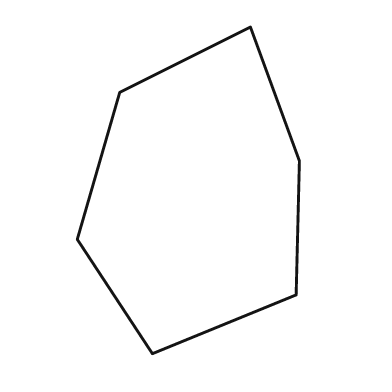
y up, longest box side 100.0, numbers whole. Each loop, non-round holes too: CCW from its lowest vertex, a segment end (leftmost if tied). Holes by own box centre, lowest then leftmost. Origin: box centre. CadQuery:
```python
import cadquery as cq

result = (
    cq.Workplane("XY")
    .moveTo(-11.0, -50.0)
    .lineTo(33.0, -32.0)
    .lineTo(34.0, 9.0)
    .lineTo(19.0, 50.0)
    .lineTo(-21.0, 30.0)
    .lineTo(-34.0, -15.0)
    .close()
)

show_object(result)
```